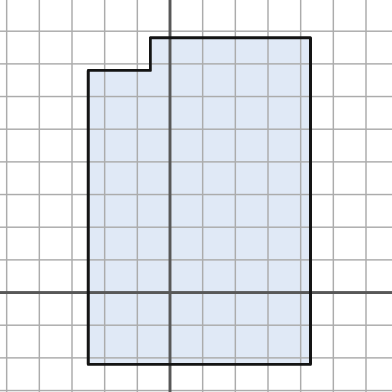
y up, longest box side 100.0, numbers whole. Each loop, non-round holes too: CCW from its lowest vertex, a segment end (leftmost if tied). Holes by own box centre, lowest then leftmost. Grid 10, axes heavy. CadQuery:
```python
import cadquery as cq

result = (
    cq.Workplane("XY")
    .moveTo(-25.0, -22.0)
    .lineTo(43.0, -22.0)
    .lineTo(43.0, 78.0)
    .lineTo(-6.0, 78.0)
    .lineTo(-6.0, 68.0)
    .lineTo(-25.0, 68.0)
    .close()
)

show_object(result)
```